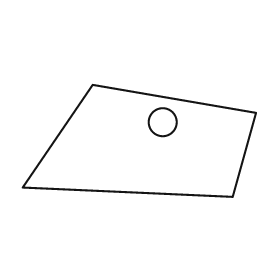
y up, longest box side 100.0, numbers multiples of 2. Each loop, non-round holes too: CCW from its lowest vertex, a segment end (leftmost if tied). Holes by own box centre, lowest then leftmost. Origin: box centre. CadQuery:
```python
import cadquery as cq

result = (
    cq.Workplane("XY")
    .moveTo(40.0, -24.0)
    .lineTo(50.0, 12.0)
    .lineTo(-20.0, 24.0)
    .lineTo(-50.0, -20.0)
    .close()
    .moveTo(10.0, 8.0)
    .circle(6.0)
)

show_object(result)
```